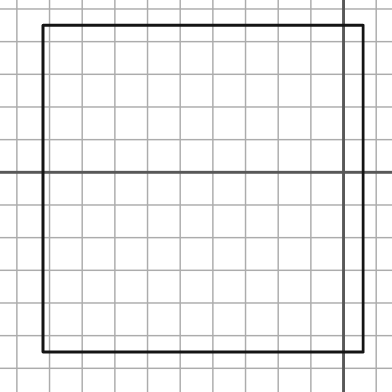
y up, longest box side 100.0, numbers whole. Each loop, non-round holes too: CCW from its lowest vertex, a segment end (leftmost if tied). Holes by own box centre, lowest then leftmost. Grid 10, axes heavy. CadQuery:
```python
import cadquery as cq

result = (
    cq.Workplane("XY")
    .moveTo(-92.0, -55.0)
    .lineTo(6.0, -55.0)
    .lineTo(6.0, 45.0)
    .lineTo(-92.0, 45.0)
    .close()
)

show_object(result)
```